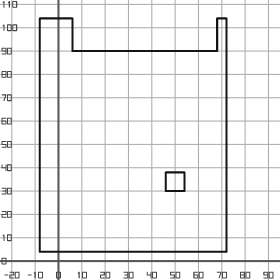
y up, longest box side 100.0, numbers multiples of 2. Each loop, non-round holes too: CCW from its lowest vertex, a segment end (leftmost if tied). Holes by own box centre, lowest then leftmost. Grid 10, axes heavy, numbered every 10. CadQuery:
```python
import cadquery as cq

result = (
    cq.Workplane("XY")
    .moveTo(-8.0, 4.0)
    .lineTo(72.0, 4.0)
    .lineTo(72.0, 104.0)
    .lineTo(68.0, 104.0)
    .lineTo(68.0, 90.0)
    .lineTo(6.0, 90.0)
    .lineTo(6.0, 104.0)
    .lineTo(-8.0, 104.0)
    .close()
    .moveTo(46.0, 30.0)
    .lineTo(54.0, 30.0)
    .lineTo(54.0, 38.0)
    .lineTo(46.0, 38.0)
    .close()
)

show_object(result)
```